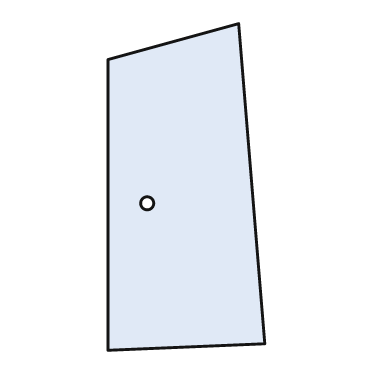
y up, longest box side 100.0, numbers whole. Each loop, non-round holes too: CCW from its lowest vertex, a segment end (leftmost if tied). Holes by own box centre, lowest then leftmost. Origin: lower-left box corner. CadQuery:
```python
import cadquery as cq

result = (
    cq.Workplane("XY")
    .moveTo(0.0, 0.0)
    .lineTo(48.0, 2.0)
    .lineTo(40.0, 100.0)
    .lineTo(0.0, 89.0)
    .close()
    .moveTo(12.0, 45.0)
    .circle(2.0)
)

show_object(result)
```